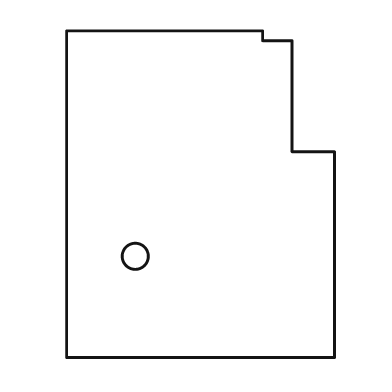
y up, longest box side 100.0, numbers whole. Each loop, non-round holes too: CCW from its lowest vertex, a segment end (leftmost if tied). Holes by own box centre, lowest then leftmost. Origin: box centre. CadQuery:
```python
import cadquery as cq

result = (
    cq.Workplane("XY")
    .moveTo(-41.0, -50.0)
    .lineTo(41.0, -50.0)
    .lineTo(41.0, 13.0)
    .lineTo(28.0, 13.0)
    .lineTo(28.0, 47.0)
    .lineTo(19.0, 47.0)
    .lineTo(19.0, 50.0)
    .lineTo(-41.0, 50.0)
    .close()
    .moveTo(-20.0, -19.0)
    .circle(4.0)
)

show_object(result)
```